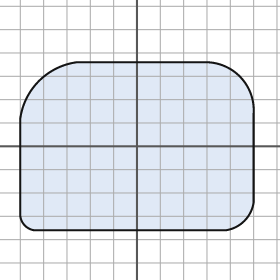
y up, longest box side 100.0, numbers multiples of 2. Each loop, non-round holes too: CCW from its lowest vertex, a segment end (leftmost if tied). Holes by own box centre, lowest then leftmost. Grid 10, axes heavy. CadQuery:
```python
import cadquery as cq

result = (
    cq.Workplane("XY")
    .moveTo(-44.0, -36.0)
    .lineTo(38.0, -36.0)
    .threePointArc((46.0, -32.0), (50.0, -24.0))
    .lineTo(50.0, 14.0)
    .threePointArc((44.0, 30.0), (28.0, 36.0))
    .lineTo(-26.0, 36.0)
    .threePointArc((-42.0, 28.0), (-50.0, 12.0))
    .lineTo(-50.0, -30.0)
    .threePointArc((-48.0, -34.0), (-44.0, -36.0))
    .close()
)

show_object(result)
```